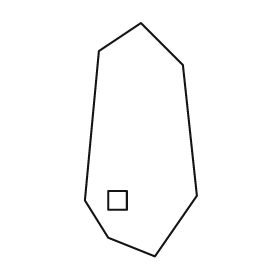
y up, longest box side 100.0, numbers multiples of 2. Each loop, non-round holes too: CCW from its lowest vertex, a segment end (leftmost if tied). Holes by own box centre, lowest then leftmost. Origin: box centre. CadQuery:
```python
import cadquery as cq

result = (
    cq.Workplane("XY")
    .moveTo(6.0, -50.0)
    .lineTo(24.0, -24.0)
    .lineTo(18.0, 32.0)
    .lineTo(0.0, 50.0)
    .lineTo(-18.0, 38.0)
    .lineTo(-24.0, -26.0)
    .lineTo(-14.0, -42.0)
    .close()
    .moveTo(-14.0, -30.0)
    .lineTo(-6.0, -30.0)
    .lineTo(-6.0, -22.0)
    .lineTo(-14.0, -22.0)
    .close()
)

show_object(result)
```